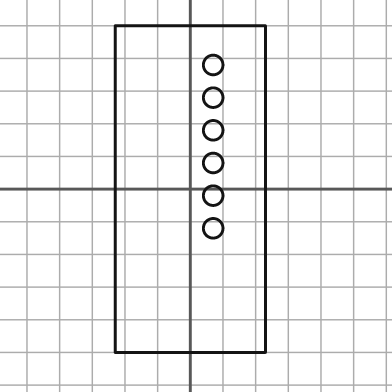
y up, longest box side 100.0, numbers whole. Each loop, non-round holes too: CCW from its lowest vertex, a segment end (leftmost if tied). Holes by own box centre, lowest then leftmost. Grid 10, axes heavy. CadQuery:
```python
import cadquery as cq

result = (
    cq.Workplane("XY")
    .moveTo(-23.0, -50.0)
    .lineTo(23.0, -50.0)
    .lineTo(23.0, 50.0)
    .lineTo(-23.0, 50.0)
    .close()
    .moveTo(7.0, -12.0)
    .circle(3.0)
    .moveTo(7.0, -2.0)
    .circle(3.0)
    .moveTo(7.0, 8.0)
    .circle(3.0)
    .moveTo(7.0, 18.0)
    .circle(3.0)
    .moveTo(7.0, 28.0)
    .circle(3.0)
    .moveTo(7.0, 38.0)
    .circle(3.0)
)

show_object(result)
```